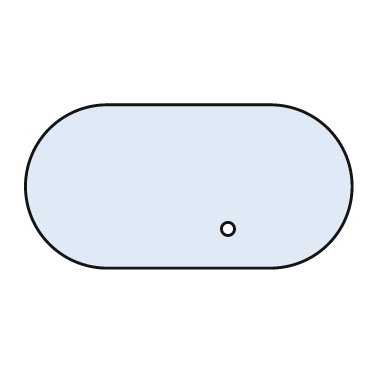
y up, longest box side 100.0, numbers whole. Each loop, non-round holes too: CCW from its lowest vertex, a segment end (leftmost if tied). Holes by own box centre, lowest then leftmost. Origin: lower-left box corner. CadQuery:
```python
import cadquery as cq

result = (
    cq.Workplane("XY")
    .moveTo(25.0, 0.0)
    .lineTo(75.0, 0.0)
    .threePointArc((100.0, 25.0), (75.0, 50.0))
    .lineTo(25.0, 50.0)
    .threePointArc((0.0, 25.0), (25.0, 0.0))
    .close()
    .moveTo(62.0, 12.0)
    .circle(2.0)
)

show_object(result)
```